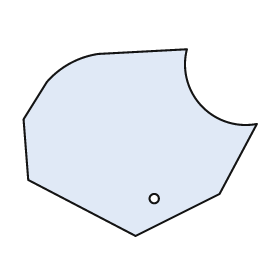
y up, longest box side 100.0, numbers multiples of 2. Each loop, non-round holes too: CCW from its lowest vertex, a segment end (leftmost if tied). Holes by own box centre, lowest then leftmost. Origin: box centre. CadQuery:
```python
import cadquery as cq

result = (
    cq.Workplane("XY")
    .moveTo(-2.0, -40.0)
    .lineTo(34.0, -22.0)
    .lineTo(50.0, 8.0)
    .threePointArc((26.0, 16.0), (20.0, 40.0))
    .lineTo(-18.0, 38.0)
    .threePointArc((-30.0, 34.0), (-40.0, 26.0))
    .lineTo(-50.0, 10.0)
    .lineTo(-48.0, -16.0)
    .close()
    .moveTo(6.0, -24.0)
    .circle(2.0)
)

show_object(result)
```